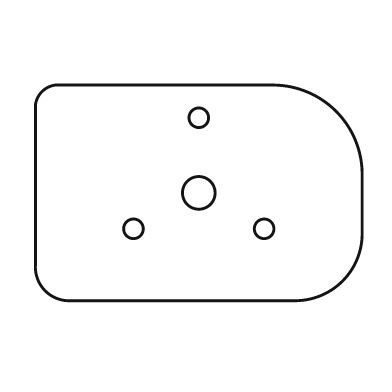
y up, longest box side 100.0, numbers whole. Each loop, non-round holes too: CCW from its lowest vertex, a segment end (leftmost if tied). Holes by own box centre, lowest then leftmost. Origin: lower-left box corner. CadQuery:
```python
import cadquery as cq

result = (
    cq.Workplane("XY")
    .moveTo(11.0, 0.0)
    .lineTo(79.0, 0.0)
    .threePointArc((94.0, 6.0), (100.0, 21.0))
    .lineTo(100.0, 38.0)
    .threePointArc((92.0, 58.0), (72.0, 66.0))
    .lineTo(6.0, 66.0)
    .threePointArc((2.0, 64.0), (0.0, 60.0))
    .lineTo(0.0, 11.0)
    .threePointArc((3.0, 3.0), (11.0, 0.0))
    .close()
    .moveTo(30.0, 22.0)
    .circle(3.0)
    .moveTo(70.0, 22.0)
    .circle(3.0)
    .moveTo(50.0, 33.0)
    .circle(5.0)
    .moveTo(50.0, 56.0)
    .circle(3.0)
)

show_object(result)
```